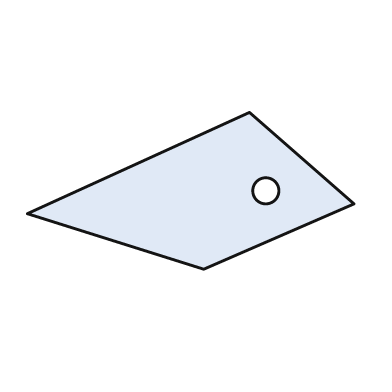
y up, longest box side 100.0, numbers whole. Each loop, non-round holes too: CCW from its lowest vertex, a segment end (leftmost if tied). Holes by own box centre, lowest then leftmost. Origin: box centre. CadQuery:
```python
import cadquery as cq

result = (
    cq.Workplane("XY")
    .moveTo(4.0, -24.0)
    .lineTo(50.0, -4.0)
    .lineTo(18.0, 24.0)
    .lineTo(-50.0, -7.0)
    .close()
    .moveTo(23.0, 0.0)
    .circle(4.0)
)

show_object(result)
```